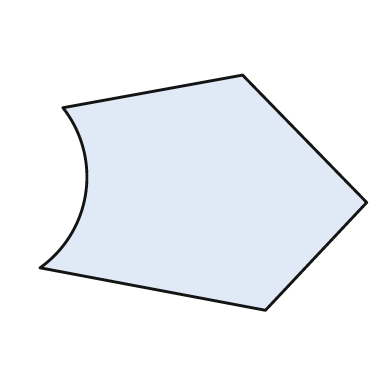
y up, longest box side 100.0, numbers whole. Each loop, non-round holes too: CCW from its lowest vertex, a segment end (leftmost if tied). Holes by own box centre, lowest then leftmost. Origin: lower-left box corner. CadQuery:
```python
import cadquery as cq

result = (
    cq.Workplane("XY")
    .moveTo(69.0, 0.0)
    .lineTo(100.0, 33.0)
    .lineTo(62.0, 72.0)
    .lineTo(7.0, 62.0)
    .threePointArc((14.0, 36.0), (0.0, 13.0))
    .close()
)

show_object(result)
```